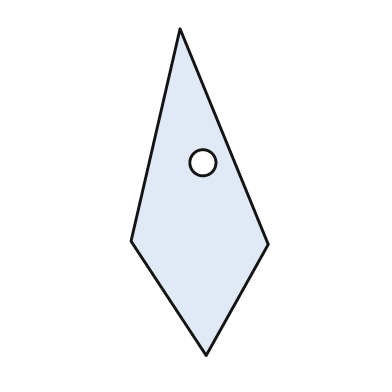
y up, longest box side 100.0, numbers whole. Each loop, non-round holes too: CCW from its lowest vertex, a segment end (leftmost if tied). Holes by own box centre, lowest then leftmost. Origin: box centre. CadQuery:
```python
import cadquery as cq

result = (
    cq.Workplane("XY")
    .moveTo(2.0, -50.0)
    .lineTo(21.0, -16.0)
    .lineTo(-6.0, 50.0)
    .lineTo(-21.0, -15.0)
    .close()
    .moveTo(1.0, 9.0)
    .circle(4.0)
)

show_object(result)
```